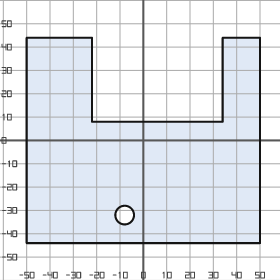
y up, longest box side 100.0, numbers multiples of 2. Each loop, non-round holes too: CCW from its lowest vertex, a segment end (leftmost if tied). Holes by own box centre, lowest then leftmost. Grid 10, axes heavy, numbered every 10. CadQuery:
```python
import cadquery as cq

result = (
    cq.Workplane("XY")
    .moveTo(-50.0, -44.0)
    .lineTo(50.0, -44.0)
    .lineTo(50.0, 44.0)
    .lineTo(34.0, 44.0)
    .lineTo(34.0, 8.0)
    .lineTo(-22.0, 8.0)
    .lineTo(-22.0, 44.0)
    .lineTo(-50.0, 44.0)
    .close()
    .moveTo(-8.0, -32.0)
    .circle(4.0)
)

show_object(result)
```